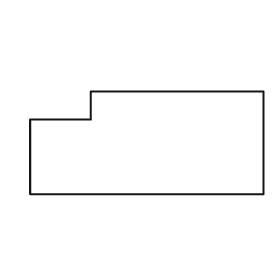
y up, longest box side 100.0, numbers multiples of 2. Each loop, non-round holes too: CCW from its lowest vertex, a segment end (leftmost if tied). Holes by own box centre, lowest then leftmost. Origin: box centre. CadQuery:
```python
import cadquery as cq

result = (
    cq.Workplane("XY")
    .moveTo(-50.0, -22.0)
    .lineTo(50.0, -22.0)
    .lineTo(50.0, 22.0)
    .lineTo(-24.0, 22.0)
    .lineTo(-24.0, 10.0)
    .lineTo(-50.0, 10.0)
    .close()
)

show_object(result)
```